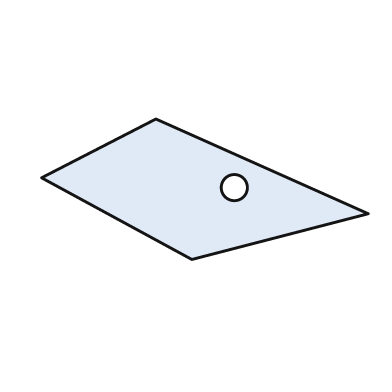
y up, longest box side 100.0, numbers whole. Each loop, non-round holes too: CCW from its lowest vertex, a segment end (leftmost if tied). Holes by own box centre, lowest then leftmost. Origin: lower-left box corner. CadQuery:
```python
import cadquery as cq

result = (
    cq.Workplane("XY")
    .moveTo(46.0, 0.0)
    .lineTo(100.0, 14.0)
    .lineTo(35.0, 43.0)
    .lineTo(0.0, 25.0)
    .close()
    .moveTo(59.0, 22.0)
    .circle(4.0)
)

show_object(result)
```